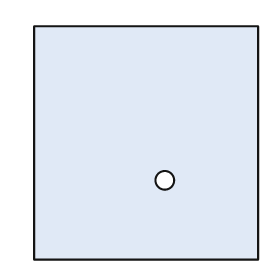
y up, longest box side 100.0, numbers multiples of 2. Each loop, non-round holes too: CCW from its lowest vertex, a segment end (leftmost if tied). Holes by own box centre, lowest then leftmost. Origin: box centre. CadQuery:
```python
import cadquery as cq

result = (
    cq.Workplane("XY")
    .moveTo(-48.0, -50.0)
    .lineTo(48.0, -50.0)
    .lineTo(48.0, 50.0)
    .lineTo(-48.0, 50.0)
    .close()
    .moveTo(8.0, -16.0)
    .circle(4.0)
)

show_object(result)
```